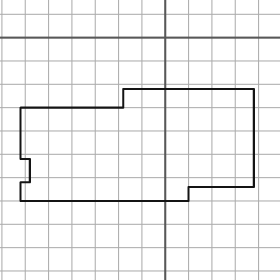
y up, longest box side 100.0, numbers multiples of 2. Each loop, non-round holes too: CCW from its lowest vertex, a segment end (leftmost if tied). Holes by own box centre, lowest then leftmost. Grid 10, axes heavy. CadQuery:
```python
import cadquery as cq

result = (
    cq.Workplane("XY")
    .moveTo(-62.0, -70.0)
    .lineTo(10.0, -70.0)
    .lineTo(10.0, -64.0)
    .lineTo(38.0, -64.0)
    .lineTo(38.0, -22.0)
    .lineTo(-18.0, -22.0)
    .lineTo(-18.0, -30.0)
    .lineTo(-62.0, -30.0)
    .lineTo(-62.0, -52.0)
    .lineTo(-58.0, -52.0)
    .lineTo(-58.0, -62.0)
    .lineTo(-62.0, -62.0)
    .close()
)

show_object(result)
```